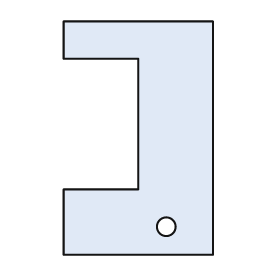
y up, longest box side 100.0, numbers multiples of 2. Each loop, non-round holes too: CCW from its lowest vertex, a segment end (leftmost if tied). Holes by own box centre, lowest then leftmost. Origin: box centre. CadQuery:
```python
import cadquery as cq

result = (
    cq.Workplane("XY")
    .moveTo(-32.0, -50.0)
    .lineTo(32.0, -50.0)
    .lineTo(32.0, 50.0)
    .lineTo(-32.0, 50.0)
    .lineTo(-32.0, 34.0)
    .lineTo(0.0, 34.0)
    .lineTo(0.0, -22.0)
    .lineTo(-32.0, -22.0)
    .close()
    .moveTo(12.0, -38.0)
    .circle(4.0)
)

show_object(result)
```